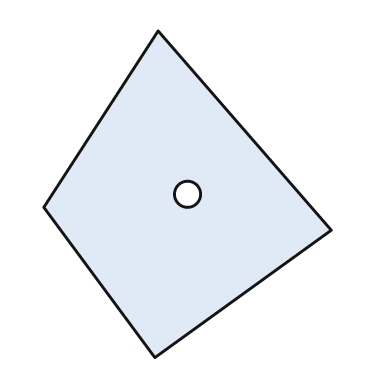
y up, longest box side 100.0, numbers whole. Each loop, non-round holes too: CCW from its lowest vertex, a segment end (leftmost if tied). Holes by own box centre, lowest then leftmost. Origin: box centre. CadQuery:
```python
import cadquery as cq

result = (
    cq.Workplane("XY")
    .moveTo(-10.0, -50.0)
    .lineTo(44.0, -11.0)
    .lineTo(-9.0, 50.0)
    .lineTo(-44.0, -4.0)
    .close()
    .moveTo(0.0, 0.0)
    .circle(4.0)
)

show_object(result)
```